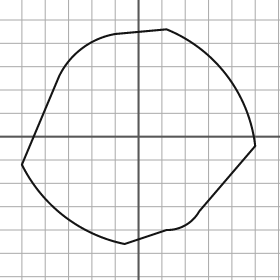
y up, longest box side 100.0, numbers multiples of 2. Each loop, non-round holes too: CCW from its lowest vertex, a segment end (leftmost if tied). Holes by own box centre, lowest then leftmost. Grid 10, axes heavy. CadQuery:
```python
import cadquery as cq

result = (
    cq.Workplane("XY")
    .moveTo(-6.0, -46.0)
    .lineTo(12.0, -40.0)
    .threePointArc((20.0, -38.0), (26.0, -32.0))
    .lineTo(50.0, -4.0)
    .threePointArc((38.0, 26.0), (12.0, 46.0))
    .lineTo(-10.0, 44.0)
    .threePointArc((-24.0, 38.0), (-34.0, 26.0))
    .lineTo(-50.0, -12.0)
    .threePointArc((-32.0, -34.0), (-6.0, -46.0))
    .close()
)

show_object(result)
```